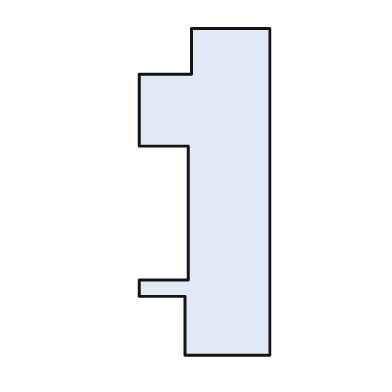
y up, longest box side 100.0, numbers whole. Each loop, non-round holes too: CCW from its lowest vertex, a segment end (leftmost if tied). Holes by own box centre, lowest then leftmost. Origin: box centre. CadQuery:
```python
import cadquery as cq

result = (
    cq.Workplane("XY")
    .moveTo(-6.0, -50.0)
    .lineTo(20.0, -50.0)
    .lineTo(20.0, 50.0)
    .lineTo(-4.0, 50.0)
    .lineTo(-4.0, 36.0)
    .lineTo(-20.0, 36.0)
    .lineTo(-20.0, 14.0)
    .lineTo(-5.0, 14.0)
    .lineTo(-5.0, -27.0)
    .lineTo(-20.0, -27.0)
    .lineTo(-20.0, -32.0)
    .lineTo(-6.0, -32.0)
    .close()
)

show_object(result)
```